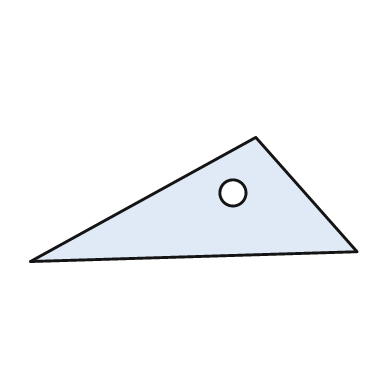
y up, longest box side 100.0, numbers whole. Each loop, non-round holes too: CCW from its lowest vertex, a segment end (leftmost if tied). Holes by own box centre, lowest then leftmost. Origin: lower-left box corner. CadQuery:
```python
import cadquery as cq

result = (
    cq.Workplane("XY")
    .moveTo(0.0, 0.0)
    .lineTo(100.0, 3.0)
    .lineTo(69.0, 38.0)
    .close()
    .moveTo(62.0, 21.0)
    .circle(4.0)
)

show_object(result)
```